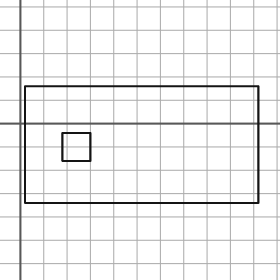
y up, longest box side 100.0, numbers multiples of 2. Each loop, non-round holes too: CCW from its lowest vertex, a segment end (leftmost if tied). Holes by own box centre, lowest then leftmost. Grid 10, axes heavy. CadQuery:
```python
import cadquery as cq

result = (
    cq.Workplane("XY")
    .moveTo(2.0, -34.0)
    .lineTo(102.0, -34.0)
    .lineTo(102.0, 16.0)
    .lineTo(2.0, 16.0)
    .close()
    .moveTo(18.0, -16.0)
    .lineTo(30.0, -16.0)
    .lineTo(30.0, -4.0)
    .lineTo(18.0, -4.0)
    .close()
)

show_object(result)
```